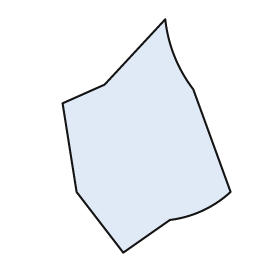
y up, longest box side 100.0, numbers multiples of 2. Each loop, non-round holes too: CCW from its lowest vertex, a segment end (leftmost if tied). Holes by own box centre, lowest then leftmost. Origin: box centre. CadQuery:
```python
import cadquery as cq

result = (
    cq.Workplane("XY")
    .moveTo(-10.0, -50.0)
    .lineTo(10.0, -36.0)
    .threePointArc((24.0, -32.0), (36.0, -24.0))
    .lineTo(20.0, 20.0)
    .threePointArc((12.0, 34.0), (8.0, 50.0))
    .lineTo(-18.0, 22.0)
    .lineTo(-36.0, 14.0)
    .lineTo(-30.0, -24.0)
    .close()
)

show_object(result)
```